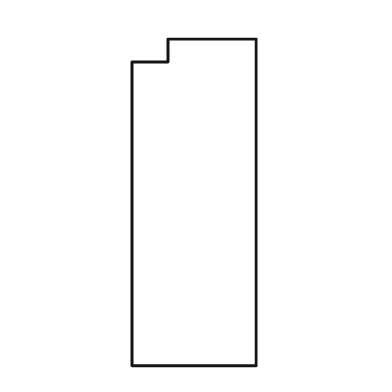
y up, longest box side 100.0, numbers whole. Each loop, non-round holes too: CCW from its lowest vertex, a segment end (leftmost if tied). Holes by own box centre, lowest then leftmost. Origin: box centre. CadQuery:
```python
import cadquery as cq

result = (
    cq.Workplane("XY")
    .moveTo(-19.0, -50.0)
    .lineTo(19.0, -50.0)
    .lineTo(19.0, 50.0)
    .lineTo(-8.0, 50.0)
    .lineTo(-8.0, 43.0)
    .lineTo(-19.0, 43.0)
    .close()
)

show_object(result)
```